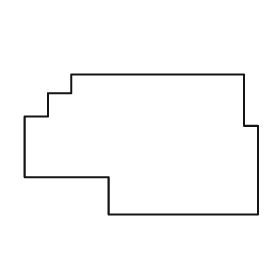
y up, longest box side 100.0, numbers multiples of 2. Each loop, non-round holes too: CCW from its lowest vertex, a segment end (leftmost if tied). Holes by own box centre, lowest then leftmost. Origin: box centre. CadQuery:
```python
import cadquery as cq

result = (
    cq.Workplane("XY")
    .moveTo(-14.0, -30.0)
    .lineTo(50.0, -30.0)
    .lineTo(50.0, 8.0)
    .lineTo(44.0, 8.0)
    .lineTo(44.0, 30.0)
    .lineTo(-30.0, 30.0)
    .lineTo(-30.0, 22.0)
    .lineTo(-40.0, 22.0)
    .lineTo(-40.0, 12.0)
    .lineTo(-50.0, 12.0)
    .lineTo(-50.0, -14.0)
    .lineTo(-14.0, -14.0)
    .close()
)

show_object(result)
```